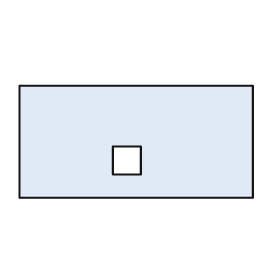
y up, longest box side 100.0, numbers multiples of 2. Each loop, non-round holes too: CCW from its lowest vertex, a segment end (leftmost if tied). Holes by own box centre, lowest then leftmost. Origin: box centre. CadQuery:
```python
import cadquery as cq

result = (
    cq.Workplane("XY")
    .moveTo(-50.0, -24.0)
    .lineTo(50.0, -24.0)
    .lineTo(50.0, 24.0)
    .lineTo(-50.0, 24.0)
    .close()
    .moveTo(-10.0, -14.0)
    .lineTo(2.0, -14.0)
    .lineTo(2.0, -2.0)
    .lineTo(-10.0, -2.0)
    .close()
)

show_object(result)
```